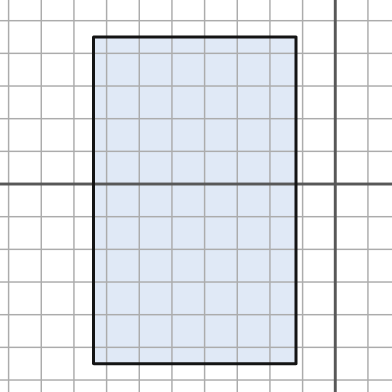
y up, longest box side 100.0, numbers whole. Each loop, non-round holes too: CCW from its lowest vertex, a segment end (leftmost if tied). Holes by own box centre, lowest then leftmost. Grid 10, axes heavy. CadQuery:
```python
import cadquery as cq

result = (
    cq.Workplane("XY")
    .moveTo(-74.0, -55.0)
    .lineTo(-12.0, -55.0)
    .lineTo(-12.0, 45.0)
    .lineTo(-74.0, 45.0)
    .close()
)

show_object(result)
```